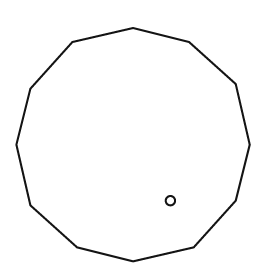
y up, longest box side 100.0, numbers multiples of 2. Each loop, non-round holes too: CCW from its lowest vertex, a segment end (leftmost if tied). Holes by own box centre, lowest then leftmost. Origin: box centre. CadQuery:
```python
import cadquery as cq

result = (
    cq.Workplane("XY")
    .moveTo(0.0, -50.0)
    .lineTo(26.0, -44.0)
    .lineTo(44.0, -24.0)
    .lineTo(50.0, 0.0)
    .lineTo(44.0, 26.0)
    .lineTo(24.0, 44.0)
    .lineTo(0.0, 50.0)
    .lineTo(-26.0, 44.0)
    .lineTo(-44.0, 24.0)
    .lineTo(-50.0, 0.0)
    .lineTo(-44.0, -26.0)
    .lineTo(-24.0, -44.0)
    .close()
    .moveTo(16.0, -24.0)
    .circle(2.0)
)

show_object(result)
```